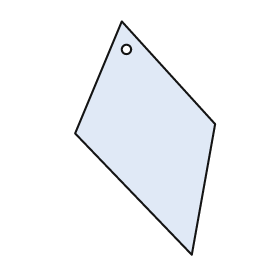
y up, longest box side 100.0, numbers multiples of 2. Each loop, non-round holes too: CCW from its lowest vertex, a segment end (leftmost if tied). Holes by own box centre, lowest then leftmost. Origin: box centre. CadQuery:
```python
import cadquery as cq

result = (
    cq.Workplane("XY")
    .moveTo(20.0, -50.0)
    .lineTo(30.0, 6.0)
    .lineTo(-10.0, 50.0)
    .lineTo(-30.0, 2.0)
    .close()
    .moveTo(-8.0, 38.0)
    .circle(2.0)
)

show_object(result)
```